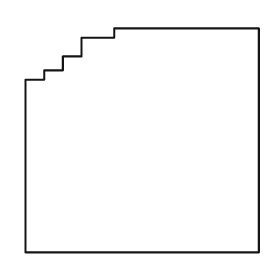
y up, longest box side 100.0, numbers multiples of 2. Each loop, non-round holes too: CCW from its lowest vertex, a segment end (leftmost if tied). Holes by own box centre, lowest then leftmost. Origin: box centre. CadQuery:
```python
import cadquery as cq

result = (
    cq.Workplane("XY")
    .moveTo(-50.0, -48.0)
    .lineTo(50.0, -48.0)
    .lineTo(50.0, 48.0)
    .lineTo(-12.0, 48.0)
    .lineTo(-12.0, 44.0)
    .lineTo(-26.0, 44.0)
    .lineTo(-26.0, 36.0)
    .lineTo(-34.0, 36.0)
    .lineTo(-34.0, 30.0)
    .lineTo(-42.0, 30.0)
    .lineTo(-42.0, 26.0)
    .lineTo(-50.0, 26.0)
    .close()
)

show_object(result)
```